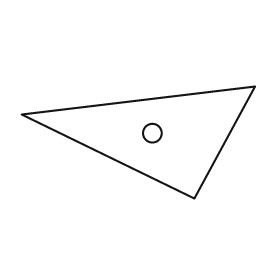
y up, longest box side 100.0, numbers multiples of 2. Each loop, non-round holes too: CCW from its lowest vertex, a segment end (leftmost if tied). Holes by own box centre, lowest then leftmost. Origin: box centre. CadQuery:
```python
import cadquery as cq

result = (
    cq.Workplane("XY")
    .moveTo(24.0, -24.0)
    .lineTo(50.0, 24.0)
    .lineTo(-50.0, 12.0)
    .close()
    .moveTo(6.0, 4.0)
    .circle(4.0)
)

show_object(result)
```